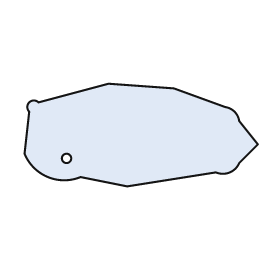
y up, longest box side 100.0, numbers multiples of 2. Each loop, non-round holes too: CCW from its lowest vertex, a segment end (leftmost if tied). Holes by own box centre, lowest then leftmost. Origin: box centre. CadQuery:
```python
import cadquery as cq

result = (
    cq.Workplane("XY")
    .moveTo(-6.0, -22.0)
    .lineTo(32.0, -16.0)
    .threePointArc((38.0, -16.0), (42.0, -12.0))
    .lineTo(50.0, -4.0)
    .lineTo(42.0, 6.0)
    .threePointArc((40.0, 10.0), (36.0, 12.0))
    .lineTo(14.0, 20.0)
    .lineTo(-14.0, 22.0)
    .lineTo(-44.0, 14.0)
    .threePointArc((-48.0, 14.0), (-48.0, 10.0))
    .lineTo(-50.0, -8.0)
    .threePointArc((-40.0, -18.0), (-26.0, -18.0))
    .close()
    .moveTo(-32.0, -10.0)
    .circle(2.0)
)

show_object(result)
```